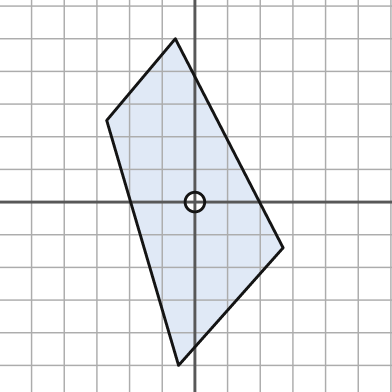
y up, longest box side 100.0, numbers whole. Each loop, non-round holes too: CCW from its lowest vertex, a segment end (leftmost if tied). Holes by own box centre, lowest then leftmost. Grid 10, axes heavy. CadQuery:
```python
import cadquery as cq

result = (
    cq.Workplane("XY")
    .moveTo(-5.0, -50.0)
    .lineTo(27.0, -14.0)
    .lineTo(-6.0, 50.0)
    .lineTo(-27.0, 25.0)
    .close()
    .moveTo(0.0, 0.0)
    .circle(3.0)
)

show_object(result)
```